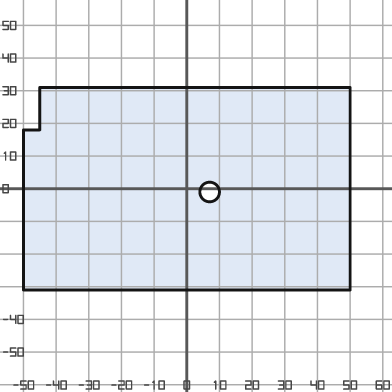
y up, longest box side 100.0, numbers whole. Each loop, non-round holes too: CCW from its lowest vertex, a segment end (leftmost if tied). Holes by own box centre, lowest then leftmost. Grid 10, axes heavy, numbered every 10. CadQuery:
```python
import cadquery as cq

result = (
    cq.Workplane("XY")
    .moveTo(-50.0, -31.0)
    .lineTo(50.0, -31.0)
    .lineTo(50.0, 31.0)
    .lineTo(-45.0, 31.0)
    .lineTo(-45.0, 18.0)
    .lineTo(-50.0, 18.0)
    .close()
    .moveTo(7.0, -1.0)
    .circle(3.0)
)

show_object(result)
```